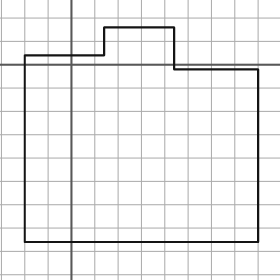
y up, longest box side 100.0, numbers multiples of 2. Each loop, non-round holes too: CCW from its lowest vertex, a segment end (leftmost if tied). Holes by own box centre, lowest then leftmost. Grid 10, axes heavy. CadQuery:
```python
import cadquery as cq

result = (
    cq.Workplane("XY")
    .moveTo(-20.0, -76.0)
    .lineTo(80.0, -76.0)
    .lineTo(80.0, -2.0)
    .lineTo(44.0, -2.0)
    .lineTo(44.0, 16.0)
    .lineTo(14.0, 16.0)
    .lineTo(14.0, 4.0)
    .lineTo(-20.0, 4.0)
    .close()
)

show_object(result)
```